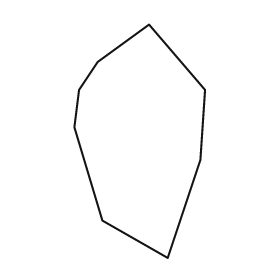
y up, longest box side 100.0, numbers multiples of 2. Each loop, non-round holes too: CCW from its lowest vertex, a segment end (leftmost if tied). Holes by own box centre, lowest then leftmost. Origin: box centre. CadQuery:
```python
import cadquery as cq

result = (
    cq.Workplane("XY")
    .moveTo(12.0, -50.0)
    .lineTo(26.0, -8.0)
    .lineTo(28.0, 22.0)
    .lineTo(4.0, 50.0)
    .lineTo(-18.0, 34.0)
    .lineTo(-26.0, 22.0)
    .lineTo(-28.0, 6.0)
    .lineTo(-16.0, -34.0)
    .close()
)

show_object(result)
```